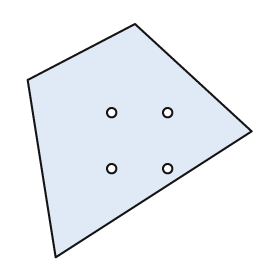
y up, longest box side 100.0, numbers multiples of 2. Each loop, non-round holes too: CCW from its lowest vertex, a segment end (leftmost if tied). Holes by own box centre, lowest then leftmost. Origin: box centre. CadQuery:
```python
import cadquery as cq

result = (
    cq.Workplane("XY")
    .moveTo(-36.0, -50.0)
    .lineTo(48.0, 4.0)
    .lineTo(-2.0, 50.0)
    .lineTo(-48.0, 26.0)
    .close()
    .moveTo(-12.0, -12.0)
    .circle(2.0)
    .moveTo(12.0, -12.0)
    .circle(2.0)
    .moveTo(-12.0, 12.0)
    .circle(2.0)
    .moveTo(12.0, 12.0)
    .circle(2.0)
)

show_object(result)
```